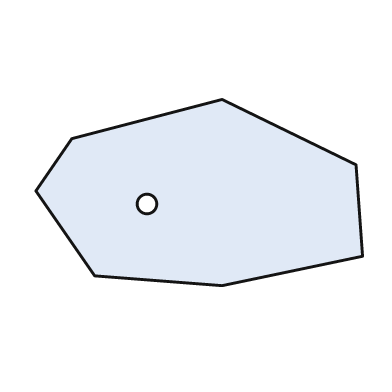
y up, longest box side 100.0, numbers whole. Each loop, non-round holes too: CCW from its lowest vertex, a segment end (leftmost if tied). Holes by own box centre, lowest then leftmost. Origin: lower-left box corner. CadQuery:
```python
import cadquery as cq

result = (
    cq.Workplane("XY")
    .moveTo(57.0, 0.0)
    .lineTo(100.0, 9.0)
    .lineTo(98.0, 37.0)
    .lineTo(57.0, 57.0)
    .lineTo(11.0, 45.0)
    .lineTo(0.0, 29.0)
    .lineTo(18.0, 3.0)
    .close()
    .moveTo(34.0, 25.0)
    .circle(3.0)
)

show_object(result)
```